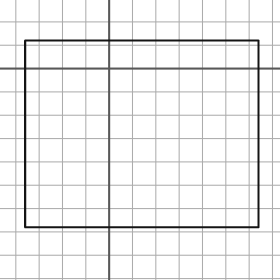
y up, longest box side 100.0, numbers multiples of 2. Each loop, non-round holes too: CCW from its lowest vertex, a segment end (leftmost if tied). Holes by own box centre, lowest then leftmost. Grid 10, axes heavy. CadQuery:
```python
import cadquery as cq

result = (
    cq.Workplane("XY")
    .moveTo(-36.0, -68.0)
    .lineTo(64.0, -68.0)
    .lineTo(64.0, 12.0)
    .lineTo(-36.0, 12.0)
    .close()
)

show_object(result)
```